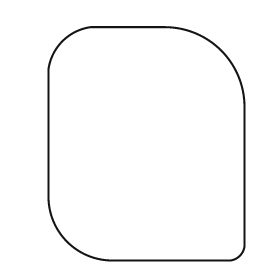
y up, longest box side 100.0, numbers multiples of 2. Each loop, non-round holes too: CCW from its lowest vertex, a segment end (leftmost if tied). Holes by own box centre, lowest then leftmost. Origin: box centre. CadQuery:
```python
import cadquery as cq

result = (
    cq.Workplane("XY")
    .moveTo(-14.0, -50.0)
    .lineTo(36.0, -50.0)
    .threePointArc((40.0, -48.0), (42.0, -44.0))
    .lineTo(42.0, 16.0)
    .threePointArc((32.0, 40.0), (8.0, 50.0))
    .lineTo(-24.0, 50.0)
    .threePointArc((-36.0, 44.0), (-42.0, 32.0))
    .lineTo(-42.0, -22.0)
    .threePointArc((-34.0, -42.0), (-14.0, -50.0))
    .close()
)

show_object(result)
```